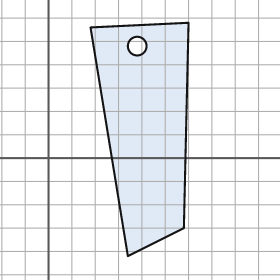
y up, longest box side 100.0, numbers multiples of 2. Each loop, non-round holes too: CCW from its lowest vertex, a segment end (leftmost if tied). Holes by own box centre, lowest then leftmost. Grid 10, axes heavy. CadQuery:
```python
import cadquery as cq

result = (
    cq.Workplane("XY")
    .moveTo(34.0, -42.0)
    .lineTo(58.0, -30.0)
    .lineTo(60.0, 58.0)
    .lineTo(18.0, 56.0)
    .close()
    .moveTo(38.0, 48.0)
    .circle(4.0)
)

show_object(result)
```